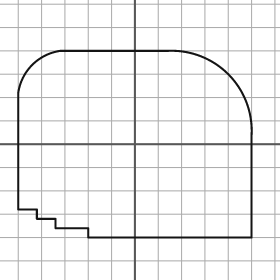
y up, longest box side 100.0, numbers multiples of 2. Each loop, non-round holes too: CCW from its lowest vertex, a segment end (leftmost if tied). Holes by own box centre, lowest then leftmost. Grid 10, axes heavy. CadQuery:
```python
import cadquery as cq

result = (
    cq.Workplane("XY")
    .moveTo(-20.0, -40.0)
    .lineTo(50.0, -40.0)
    .lineTo(50.0, 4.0)
    .threePointArc((40.0, 30.0), (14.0, 40.0))
    .lineTo(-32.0, 40.0)
    .threePointArc((-44.0, 34.0), (-50.0, 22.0))
    .lineTo(-50.0, -28.0)
    .lineTo(-42.0, -28.0)
    .lineTo(-42.0, -32.0)
    .lineTo(-34.0, -32.0)
    .lineTo(-34.0, -36.0)
    .lineTo(-20.0, -36.0)
    .close()
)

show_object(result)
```